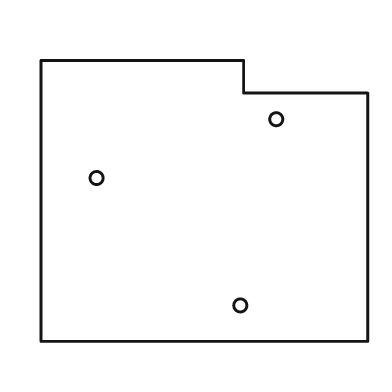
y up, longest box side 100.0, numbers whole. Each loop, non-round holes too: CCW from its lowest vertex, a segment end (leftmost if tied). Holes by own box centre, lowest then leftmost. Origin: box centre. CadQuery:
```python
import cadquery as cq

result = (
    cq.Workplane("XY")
    .moveTo(-50.0, -43.0)
    .lineTo(50.0, -43.0)
    .lineTo(50.0, 33.0)
    .lineTo(12.0, 33.0)
    .lineTo(12.0, 43.0)
    .lineTo(-50.0, 43.0)
    .close()
    .moveTo(11.0, -32.0)
    .circle(2.0)
    .moveTo(-33.0, 7.0)
    .circle(2.0)
    .moveTo(22.0, 25.0)
    .circle(2.0)
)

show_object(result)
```